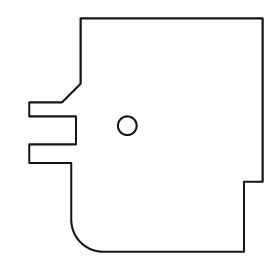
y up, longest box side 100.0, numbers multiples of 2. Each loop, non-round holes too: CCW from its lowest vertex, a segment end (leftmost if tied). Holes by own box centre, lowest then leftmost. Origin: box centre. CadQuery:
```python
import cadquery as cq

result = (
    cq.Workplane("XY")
    .moveTo(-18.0, -50.0)
    .lineTo(42.0, -50.0)
    .lineTo(42.0, -20.0)
    .lineTo(50.0, -20.0)
    .lineTo(50.0, 50.0)
    .lineTo(-28.0, 50.0)
    .lineTo(-28.0, 22.0)
    .lineTo(-36.0, 14.0)
    .lineTo(-50.0, 14.0)
    .lineTo(-50.0, 8.0)
    .lineTo(-30.0, 8.0)
    .lineTo(-30.0, -4.0)
    .lineTo(-50.0, -4.0)
    .lineTo(-50.0, -12.0)
    .lineTo(-32.0, -12.0)
    .lineTo(-32.0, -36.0)
    .threePointArc((-28.0, -46.0), (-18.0, -50.0))
    .close()
    .moveTo(-8.0, 4.0)
    .circle(4.0)
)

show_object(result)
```